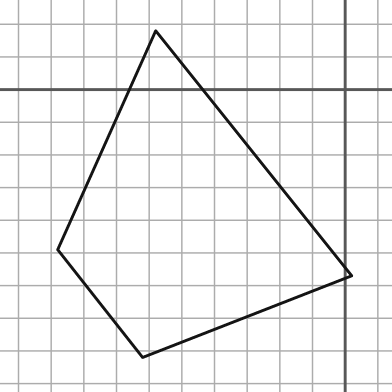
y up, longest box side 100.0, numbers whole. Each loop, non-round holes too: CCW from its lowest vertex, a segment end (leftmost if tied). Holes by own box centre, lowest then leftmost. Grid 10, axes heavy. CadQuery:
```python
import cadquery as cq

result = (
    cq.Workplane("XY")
    .moveTo(-62.0, -82.0)
    .lineTo(2.0, -57.0)
    .lineTo(-58.0, 18.0)
    .lineTo(-88.0, -49.0)
    .close()
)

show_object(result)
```